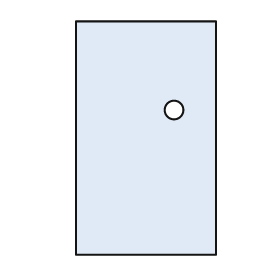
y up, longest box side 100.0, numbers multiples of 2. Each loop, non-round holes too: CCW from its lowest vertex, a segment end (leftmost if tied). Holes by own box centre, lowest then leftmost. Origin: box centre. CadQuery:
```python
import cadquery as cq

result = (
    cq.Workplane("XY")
    .moveTo(-30.0, -50.0)
    .lineTo(30.0, -50.0)
    .lineTo(30.0, 50.0)
    .lineTo(-30.0, 50.0)
    .close()
    .moveTo(12.0, 12.0)
    .circle(4.0)
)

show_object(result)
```